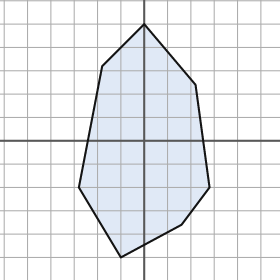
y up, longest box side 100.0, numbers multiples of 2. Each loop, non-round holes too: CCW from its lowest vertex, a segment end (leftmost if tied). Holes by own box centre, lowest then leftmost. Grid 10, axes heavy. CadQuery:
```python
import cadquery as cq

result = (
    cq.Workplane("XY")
    .moveTo(-10.0, -50.0)
    .lineTo(16.0, -36.0)
    .lineTo(28.0, -20.0)
    .lineTo(22.0, 24.0)
    .lineTo(0.0, 50.0)
    .lineTo(-18.0, 32.0)
    .lineTo(-28.0, -20.0)
    .close()
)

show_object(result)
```